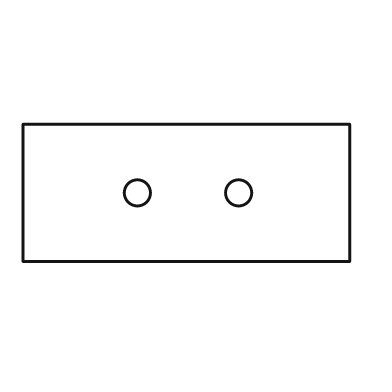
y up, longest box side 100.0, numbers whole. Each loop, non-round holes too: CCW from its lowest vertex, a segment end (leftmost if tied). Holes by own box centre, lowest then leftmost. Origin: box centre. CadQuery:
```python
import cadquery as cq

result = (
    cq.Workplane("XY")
    .moveTo(-50.0, -21.0)
    .lineTo(50.0, -21.0)
    .lineTo(50.0, 21.0)
    .lineTo(-50.0, 21.0)
    .close()
    .moveTo(-15.0, 0.0)
    .circle(4.0)
    .moveTo(16.0, 0.0)
    .circle(4.0)
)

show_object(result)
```